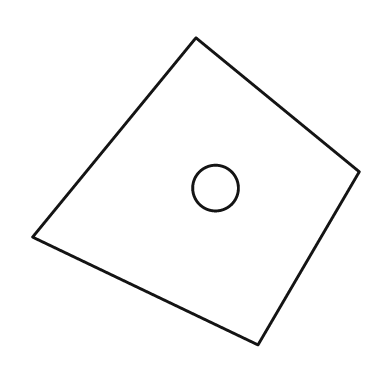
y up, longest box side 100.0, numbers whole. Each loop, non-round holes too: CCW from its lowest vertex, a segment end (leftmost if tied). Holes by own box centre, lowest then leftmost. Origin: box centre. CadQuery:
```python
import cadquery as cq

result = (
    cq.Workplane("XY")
    .moveTo(19.0, -47.0)
    .lineTo(50.0, 6.0)
    .lineTo(0.0, 47.0)
    .lineTo(-50.0, -14.0)
    .close()
    .moveTo(6.0, 1.0)
    .circle(7.0)
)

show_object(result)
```